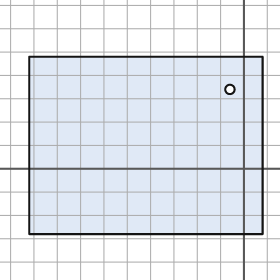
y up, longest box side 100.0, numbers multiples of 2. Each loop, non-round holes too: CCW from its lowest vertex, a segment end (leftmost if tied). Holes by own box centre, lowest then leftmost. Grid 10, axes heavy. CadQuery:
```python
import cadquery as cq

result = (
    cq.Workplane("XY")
    .moveTo(-92.0, -28.0)
    .lineTo(8.0, -28.0)
    .lineTo(8.0, 48.0)
    .lineTo(-92.0, 48.0)
    .close()
    .moveTo(-6.0, 34.0)
    .circle(2.0)
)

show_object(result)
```